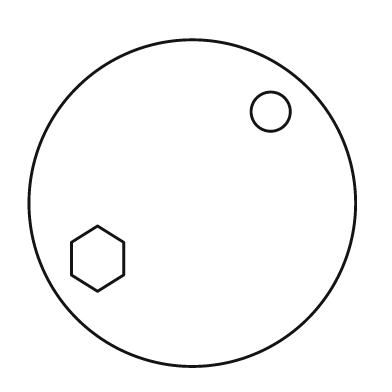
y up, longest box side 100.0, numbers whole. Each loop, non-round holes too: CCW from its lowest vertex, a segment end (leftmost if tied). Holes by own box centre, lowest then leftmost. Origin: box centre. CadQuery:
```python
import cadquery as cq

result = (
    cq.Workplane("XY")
    .moveTo(0.0, 0.0)
    .circle(50.0)
    .moveTo(-29.0, -27.0)
    .lineTo(-21.0, -22.0)
    .lineTo(-21.0, -12.0)
    .lineTo(-29.0, -7.0)
    .lineTo(-37.0, -12.0)
    .lineTo(-37.0, -22.0)
    .close()
    .moveTo(24.0, 28.0)
    .circle(6.0)
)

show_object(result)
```